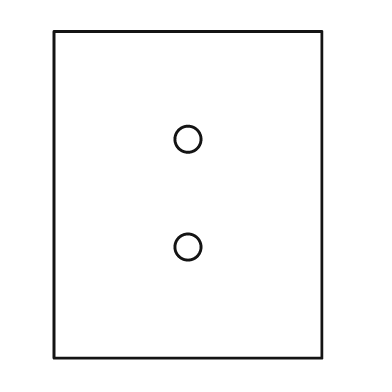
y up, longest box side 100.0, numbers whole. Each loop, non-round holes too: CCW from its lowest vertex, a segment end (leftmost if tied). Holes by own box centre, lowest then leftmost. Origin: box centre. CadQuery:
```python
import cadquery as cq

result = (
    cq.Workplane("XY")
    .moveTo(-41.0, -50.0)
    .lineTo(41.0, -50.0)
    .lineTo(41.0, 50.0)
    .lineTo(-41.0, 50.0)
    .close()
    .moveTo(0.0, -16.0)
    .circle(4.0)
    .moveTo(0.0, 17.0)
    .circle(4.0)
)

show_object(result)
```